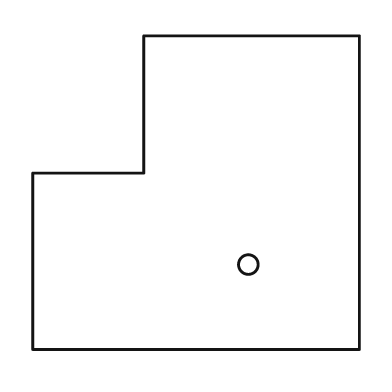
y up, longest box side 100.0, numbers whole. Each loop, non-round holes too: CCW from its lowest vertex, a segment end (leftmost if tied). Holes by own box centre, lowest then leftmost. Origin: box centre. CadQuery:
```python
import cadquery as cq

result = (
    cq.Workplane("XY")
    .moveTo(-50.0, -48.0)
    .lineTo(50.0, -48.0)
    .lineTo(50.0, 48.0)
    .lineTo(-16.0, 48.0)
    .lineTo(-16.0, 6.0)
    .lineTo(-50.0, 6.0)
    .close()
    .moveTo(16.0, -22.0)
    .circle(3.0)
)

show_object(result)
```